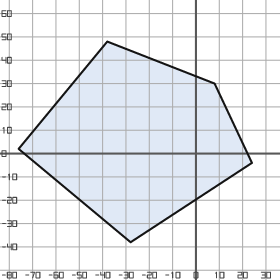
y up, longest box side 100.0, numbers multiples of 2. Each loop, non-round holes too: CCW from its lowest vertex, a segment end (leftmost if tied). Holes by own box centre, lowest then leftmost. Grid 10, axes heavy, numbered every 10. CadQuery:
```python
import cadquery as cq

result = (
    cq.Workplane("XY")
    .moveTo(-28.0, -38.0)
    .lineTo(24.0, -4.0)
    .lineTo(8.0, 30.0)
    .lineTo(-38.0, 48.0)
    .lineTo(-76.0, 2.0)
    .close()
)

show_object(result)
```